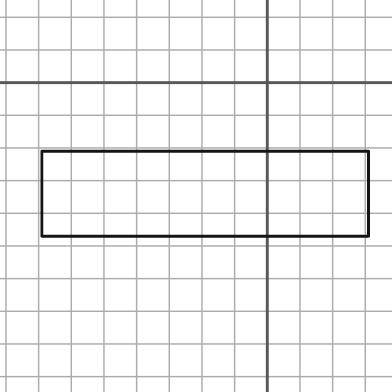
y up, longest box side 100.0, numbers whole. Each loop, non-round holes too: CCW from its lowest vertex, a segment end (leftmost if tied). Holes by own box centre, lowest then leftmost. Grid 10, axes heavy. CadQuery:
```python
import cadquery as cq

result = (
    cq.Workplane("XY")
    .moveTo(-69.0, -47.0)
    .lineTo(31.0, -47.0)
    .lineTo(31.0, -21.0)
    .lineTo(-69.0, -21.0)
    .close()
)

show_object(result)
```